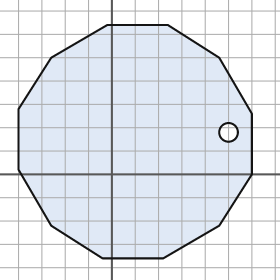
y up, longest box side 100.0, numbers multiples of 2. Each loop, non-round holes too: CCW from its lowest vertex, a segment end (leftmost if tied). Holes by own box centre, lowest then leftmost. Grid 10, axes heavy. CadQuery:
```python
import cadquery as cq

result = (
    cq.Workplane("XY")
    .moveTo(-4.0, -36.0)
    .lineTo(22.0, -36.0)
    .lineTo(46.0, -22.0)
    .lineTo(60.0, 0.0)
    .lineTo(60.0, 26.0)
    .lineTo(46.0, 50.0)
    .lineTo(24.0, 64.0)
    .lineTo(-2.0, 64.0)
    .lineTo(-26.0, 50.0)
    .lineTo(-40.0, 28.0)
    .lineTo(-40.0, 2.0)
    .lineTo(-26.0, -22.0)
    .close()
    .moveTo(50.0, 18.0)
    .circle(4.0)
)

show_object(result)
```